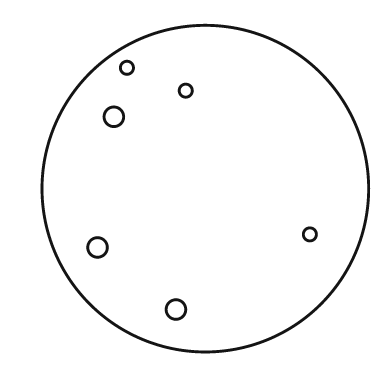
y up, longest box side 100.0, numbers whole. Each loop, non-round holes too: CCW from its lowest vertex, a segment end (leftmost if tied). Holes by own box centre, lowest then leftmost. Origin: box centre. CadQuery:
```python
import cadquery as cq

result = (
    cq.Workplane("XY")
    .moveTo(0.0, 0.0)
    .circle(50.0)
    .moveTo(-9.0, -37.0)
    .circle(3.0)
    .moveTo(-33.0, -18.0)
    .circle(3.0)
    .moveTo(32.0, -14.0)
    .circle(2.0)
    .moveTo(-28.0, 22.0)
    .circle(3.0)
    .moveTo(-6.0, 30.0)
    .circle(2.0)
    .moveTo(-24.0, 37.0)
    .circle(2.0)
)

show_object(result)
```